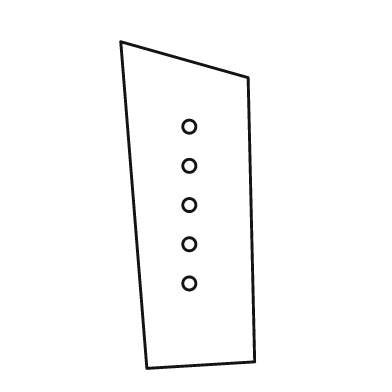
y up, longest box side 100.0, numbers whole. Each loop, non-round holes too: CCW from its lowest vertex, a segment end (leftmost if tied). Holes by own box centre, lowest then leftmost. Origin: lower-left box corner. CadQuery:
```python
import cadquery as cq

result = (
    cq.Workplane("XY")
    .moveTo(8.0, 0.0)
    .lineTo(41.0, 2.0)
    .lineTo(39.0, 89.0)
    .lineTo(0.0, 100.0)
    .close()
    .moveTo(21.0, 26.0)
    .circle(2.0)
    .moveTo(21.0, 38.0)
    .circle(2.0)
    .moveTo(21.0, 50.0)
    .circle(2.0)
    .moveTo(21.0, 62.0)
    .circle(2.0)
    .moveTo(21.0, 74.0)
    .circle(2.0)
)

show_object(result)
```